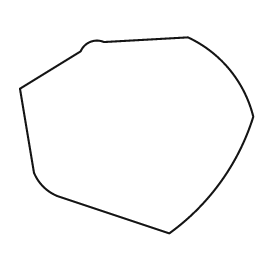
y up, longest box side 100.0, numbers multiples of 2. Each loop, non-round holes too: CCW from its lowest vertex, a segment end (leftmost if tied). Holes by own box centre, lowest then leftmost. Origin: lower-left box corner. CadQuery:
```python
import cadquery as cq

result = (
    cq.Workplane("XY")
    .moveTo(64.0, 0.0)
    .threePointArc((86.0, 22.0), (100.0, 50.0))
    .threePointArc((90.0, 70.0), (72.0, 84.0))
    .lineTo(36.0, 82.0)
    .threePointArc((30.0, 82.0), (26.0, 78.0))
    .lineTo(0.0, 62.0)
    .lineTo(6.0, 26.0)
    .threePointArc((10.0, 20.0), (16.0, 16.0))
    .close()
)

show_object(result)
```